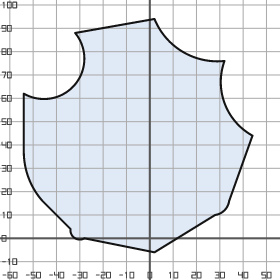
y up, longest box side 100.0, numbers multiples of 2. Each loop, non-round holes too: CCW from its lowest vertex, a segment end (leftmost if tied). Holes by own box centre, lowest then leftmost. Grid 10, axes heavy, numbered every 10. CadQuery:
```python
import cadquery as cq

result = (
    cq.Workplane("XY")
    .moveTo(2.0, -6.0)
    .lineTo(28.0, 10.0)
    .threePointArc((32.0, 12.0), (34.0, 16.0))
    .lineTo(44.0, 44.0)
    .threePointArc((32.0, 58.0), (32.0, 76.0))
    .threePointArc((14.0, 80.0), (2.0, 94.0))
    .lineTo(-32.0, 88.0)
    .threePointArc((-32.0, 66.0), (-54.0, 62.0))
    .lineTo(-54.0, 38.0)
    .threePointArc((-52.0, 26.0), (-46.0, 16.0))
    .lineTo(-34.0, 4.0)
    .threePointArc((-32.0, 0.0), (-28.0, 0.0))
    .close()
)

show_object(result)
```